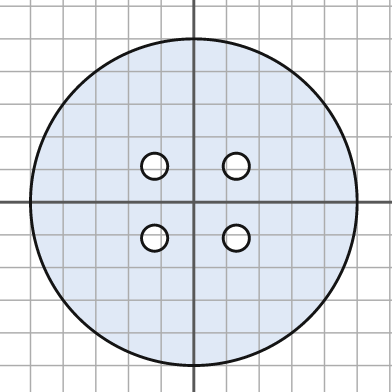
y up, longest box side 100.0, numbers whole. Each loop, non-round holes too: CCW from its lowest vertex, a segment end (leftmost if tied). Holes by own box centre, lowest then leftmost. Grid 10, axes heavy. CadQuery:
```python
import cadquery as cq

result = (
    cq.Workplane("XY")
    .moveTo(0.0, 0.0)
    .circle(50.0)
    .moveTo(-12.0, -11.0)
    .circle(4.0)
    .moveTo(13.0, -11.0)
    .circle(4.0)
    .moveTo(-12.0, 11.0)
    .circle(4.0)
    .moveTo(13.0, 11.0)
    .circle(4.0)
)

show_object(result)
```